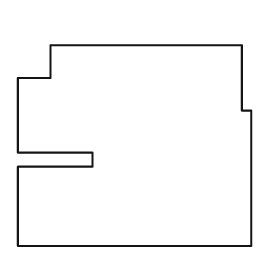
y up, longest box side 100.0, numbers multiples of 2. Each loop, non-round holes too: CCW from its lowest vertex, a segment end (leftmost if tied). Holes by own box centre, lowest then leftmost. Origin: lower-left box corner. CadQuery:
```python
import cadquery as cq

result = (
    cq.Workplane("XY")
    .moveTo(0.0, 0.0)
    .lineTo(100.0, 0.0)
    .lineTo(100.0, 58.0)
    .lineTo(96.0, 58.0)
    .lineTo(96.0, 86.0)
    .lineTo(14.0, 86.0)
    .lineTo(14.0, 72.0)
    .lineTo(0.0, 72.0)
    .lineTo(0.0, 40.0)
    .lineTo(32.0, 40.0)
    .lineTo(32.0, 34.0)
    .lineTo(0.0, 34.0)
    .close()
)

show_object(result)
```